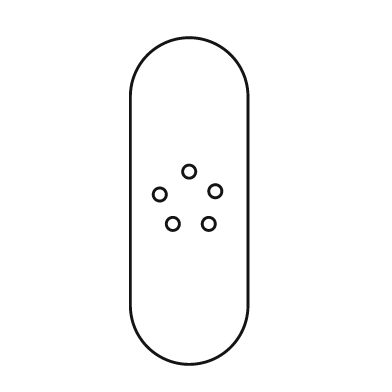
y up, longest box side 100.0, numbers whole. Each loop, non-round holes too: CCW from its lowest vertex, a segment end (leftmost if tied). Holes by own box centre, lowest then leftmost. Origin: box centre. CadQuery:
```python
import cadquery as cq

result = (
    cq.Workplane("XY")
    .moveTo(-18.0, -32.0)
    .threePointArc((0.0, -50.0), (18.0, -32.0))
    .lineTo(18.0, 32.0)
    .threePointArc((0.0, 50.0), (-18.0, 32.0))
    .close()
    .moveTo(-5.0, -7.0)
    .circle(2.0)
    .moveTo(6.0, -7.0)
    .circle(2.0)
    .moveTo(-9.0, 2.0)
    .circle(2.0)
    .moveTo(8.0, 3.0)
    .circle(2.0)
    .moveTo(0.0, 9.0)
    .circle(2.0)
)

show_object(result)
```